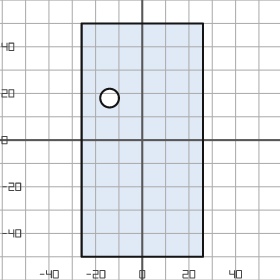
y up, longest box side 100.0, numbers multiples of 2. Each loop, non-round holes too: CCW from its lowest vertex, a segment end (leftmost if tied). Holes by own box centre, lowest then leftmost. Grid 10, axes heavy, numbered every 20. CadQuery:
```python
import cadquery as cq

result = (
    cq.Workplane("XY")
    .moveTo(-26.0, -50.0)
    .lineTo(26.0, -50.0)
    .lineTo(26.0, 50.0)
    .lineTo(-26.0, 50.0)
    .close()
    .moveTo(-14.0, 18.0)
    .circle(4.0)
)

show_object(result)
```